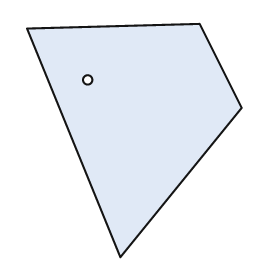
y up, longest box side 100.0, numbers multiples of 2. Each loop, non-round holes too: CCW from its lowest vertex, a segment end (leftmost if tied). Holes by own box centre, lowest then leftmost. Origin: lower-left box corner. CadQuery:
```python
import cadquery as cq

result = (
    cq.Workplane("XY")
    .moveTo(40.0, 0.0)
    .lineTo(92.0, 64.0)
    .lineTo(74.0, 100.0)
    .lineTo(0.0, 98.0)
    .close()
    .moveTo(26.0, 76.0)
    .circle(2.0)
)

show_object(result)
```